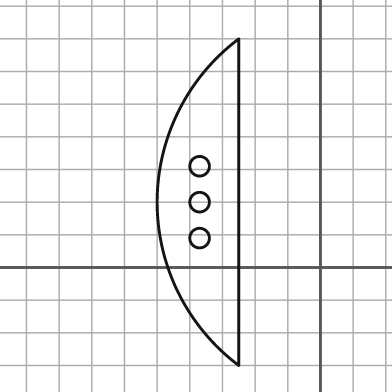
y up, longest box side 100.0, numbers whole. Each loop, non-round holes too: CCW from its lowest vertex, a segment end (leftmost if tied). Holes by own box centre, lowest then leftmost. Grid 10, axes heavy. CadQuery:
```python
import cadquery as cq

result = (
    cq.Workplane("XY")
    .moveTo(-25.0, -30.0)
    .lineTo(-25.0, 70.0)
    .threePointArc((-50.0, 20.0), (-25.0, -30.0))
    .close()
    .moveTo(-37.0, 9.0)
    .circle(3.0)
    .moveTo(-37.0, 20.0)
    .circle(3.0)
    .moveTo(-37.0, 31.0)
    .circle(3.0)
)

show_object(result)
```